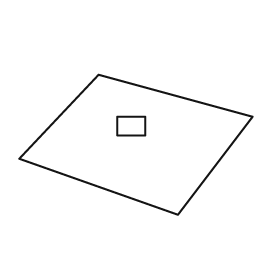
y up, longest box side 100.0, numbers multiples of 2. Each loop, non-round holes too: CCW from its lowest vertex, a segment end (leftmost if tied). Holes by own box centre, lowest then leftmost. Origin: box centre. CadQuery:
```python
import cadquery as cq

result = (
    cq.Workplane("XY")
    .moveTo(18.0, -30.0)
    .lineTo(50.0, 12.0)
    .lineTo(-16.0, 30.0)
    .lineTo(-50.0, -6.0)
    .close()
    .moveTo(-8.0, 4.0)
    .lineTo(4.0, 4.0)
    .lineTo(4.0, 12.0)
    .lineTo(-8.0, 12.0)
    .close()
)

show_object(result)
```